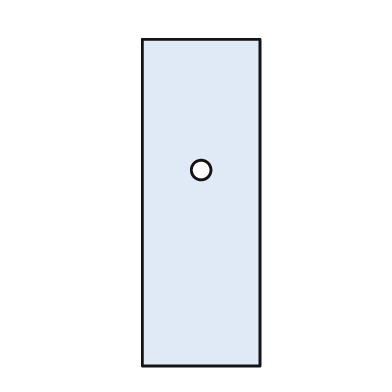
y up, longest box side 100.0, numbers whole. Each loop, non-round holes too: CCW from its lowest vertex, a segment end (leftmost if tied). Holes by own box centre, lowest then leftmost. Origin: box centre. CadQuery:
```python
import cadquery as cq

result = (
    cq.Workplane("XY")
    .moveTo(-18.0, -50.0)
    .lineTo(18.0, -50.0)
    .lineTo(18.0, 50.0)
    .lineTo(-18.0, 50.0)
    .close()
    .moveTo(0.0, 10.0)
    .circle(3.0)
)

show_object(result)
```